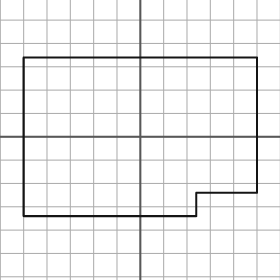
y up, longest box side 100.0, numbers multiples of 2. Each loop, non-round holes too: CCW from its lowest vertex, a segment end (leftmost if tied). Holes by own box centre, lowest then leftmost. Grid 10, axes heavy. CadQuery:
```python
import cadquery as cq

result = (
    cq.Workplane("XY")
    .moveTo(-50.0, -34.0)
    .lineTo(24.0, -34.0)
    .lineTo(24.0, -24.0)
    .lineTo(50.0, -24.0)
    .lineTo(50.0, 34.0)
    .lineTo(-50.0, 34.0)
    .close()
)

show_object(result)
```